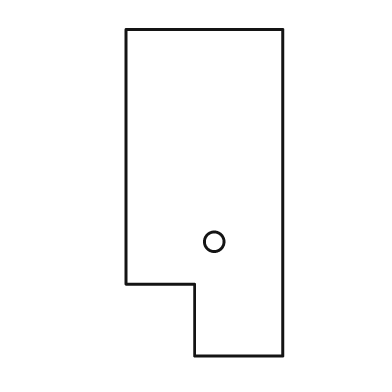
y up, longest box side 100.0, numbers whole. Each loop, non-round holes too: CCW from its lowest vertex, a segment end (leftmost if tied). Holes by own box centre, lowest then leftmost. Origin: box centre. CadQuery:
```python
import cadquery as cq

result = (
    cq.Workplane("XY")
    .moveTo(-3.0, -50.0)
    .lineTo(24.0, -50.0)
    .lineTo(24.0, 50.0)
    .lineTo(-24.0, 50.0)
    .lineTo(-24.0, -28.0)
    .lineTo(-3.0, -28.0)
    .close()
    .moveTo(3.0, -15.0)
    .circle(3.0)
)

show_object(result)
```